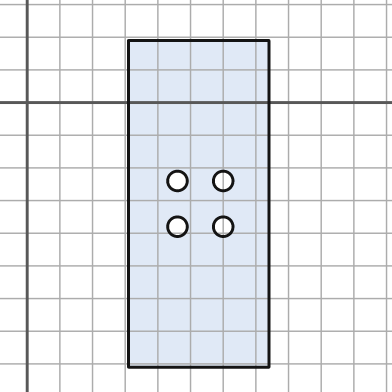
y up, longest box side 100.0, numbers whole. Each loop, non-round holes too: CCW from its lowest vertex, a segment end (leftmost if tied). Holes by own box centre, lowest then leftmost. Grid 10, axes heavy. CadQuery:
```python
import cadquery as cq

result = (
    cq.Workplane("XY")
    .moveTo(31.0, -81.0)
    .lineTo(74.0, -81.0)
    .lineTo(74.0, 19.0)
    .lineTo(31.0, 19.0)
    .close()
    .moveTo(46.0, -38.0)
    .circle(3.0)
    .moveTo(60.0, -38.0)
    .circle(3.0)
    .moveTo(46.0, -24.0)
    .circle(3.0)
    .moveTo(60.0, -24.0)
    .circle(3.0)
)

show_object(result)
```